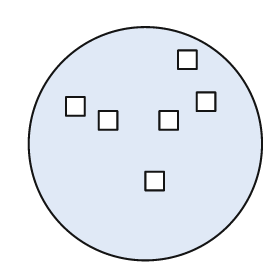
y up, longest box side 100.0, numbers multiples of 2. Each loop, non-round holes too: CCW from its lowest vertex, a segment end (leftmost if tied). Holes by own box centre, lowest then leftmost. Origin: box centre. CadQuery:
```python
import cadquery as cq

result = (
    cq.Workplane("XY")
    .moveTo(0.0, 0.0)
    .circle(50.0)
    .moveTo(0.0, -20.0)
    .lineTo(8.0, -20.0)
    .lineTo(8.0, -12.0)
    .lineTo(0.0, -12.0)
    .close()
    .moveTo(-20.0, 6.0)
    .lineTo(-12.0, 6.0)
    .lineTo(-12.0, 14.0)
    .lineTo(-20.0, 14.0)
    .close()
    .moveTo(6.0, 6.0)
    .lineTo(14.0, 6.0)
    .lineTo(14.0, 14.0)
    .lineTo(6.0, 14.0)
    .close()
    .moveTo(-34.0, 12.0)
    .lineTo(-26.0, 12.0)
    .lineTo(-26.0, 20.0)
    .lineTo(-34.0, 20.0)
    .close()
    .moveTo(22.0, 14.0)
    .lineTo(30.0, 14.0)
    .lineTo(30.0, 22.0)
    .lineTo(22.0, 22.0)
    .close()
    .moveTo(14.0, 32.0)
    .lineTo(22.0, 32.0)
    .lineTo(22.0, 40.0)
    .lineTo(14.0, 40.0)
    .close()
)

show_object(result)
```